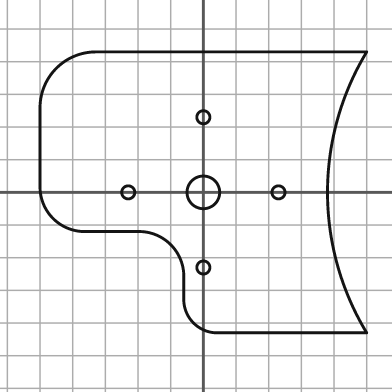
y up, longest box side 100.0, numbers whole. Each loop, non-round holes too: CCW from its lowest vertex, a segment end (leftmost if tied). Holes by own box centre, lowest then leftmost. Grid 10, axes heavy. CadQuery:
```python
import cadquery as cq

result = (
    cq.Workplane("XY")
    .moveTo(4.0, -43.0)
    .lineTo(50.0, -43.0)
    .threePointArc((38.0, 0.0), (50.0, 43.0))
    .lineTo(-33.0, 43.0)
    .threePointArc((-45.0, 38.0), (-50.0, 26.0))
    .lineTo(-50.0, 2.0)
    .threePointArc((-46.0, -8.0), (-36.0, -12.0))
    .lineTo(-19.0, -12.0)
    .threePointArc((-10.0, -16.0), (-6.0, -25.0))
    .lineTo(-6.0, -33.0)
    .threePointArc((-3.0, -40.0), (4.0, -43.0))
    .close()
    .moveTo(0.0, -23.0)
    .circle(2.0)
    .moveTo(-23.0, 0.0)
    .circle(2.0)
    .moveTo(0.0, 0.0)
    .circle(5.0)
    .moveTo(23.0, 0.0)
    .circle(2.0)
    .moveTo(0.0, 23.0)
    .circle(2.0)
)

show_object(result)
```